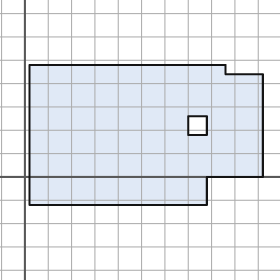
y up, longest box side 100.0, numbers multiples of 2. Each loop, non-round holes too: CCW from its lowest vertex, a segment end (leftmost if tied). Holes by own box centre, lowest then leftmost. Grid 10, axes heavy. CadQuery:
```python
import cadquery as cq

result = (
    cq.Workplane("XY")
    .moveTo(2.0, -12.0)
    .lineTo(78.0, -12.0)
    .lineTo(78.0, 0.0)
    .lineTo(102.0, 0.0)
    .lineTo(102.0, 44.0)
    .lineTo(86.0, 44.0)
    .lineTo(86.0, 48.0)
    .lineTo(2.0, 48.0)
    .close()
    .moveTo(70.0, 18.0)
    .lineTo(78.0, 18.0)
    .lineTo(78.0, 26.0)
    .lineTo(70.0, 26.0)
    .close()
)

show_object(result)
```